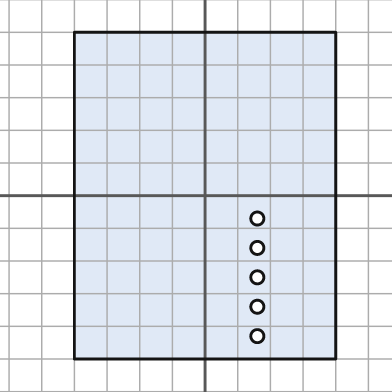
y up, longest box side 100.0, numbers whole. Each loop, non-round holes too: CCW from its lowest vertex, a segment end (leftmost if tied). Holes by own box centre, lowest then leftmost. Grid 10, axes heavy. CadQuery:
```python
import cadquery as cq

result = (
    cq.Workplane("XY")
    .moveTo(-40.0, -50.0)
    .lineTo(40.0, -50.0)
    .lineTo(40.0, 50.0)
    .lineTo(-40.0, 50.0)
    .close()
    .moveTo(16.0, -43.0)
    .circle(2.0)
    .moveTo(16.0, -34.0)
    .circle(2.0)
    .moveTo(16.0, -25.0)
    .circle(2.0)
    .moveTo(16.0, -16.0)
    .circle(2.0)
    .moveTo(16.0, -7.0)
    .circle(2.0)
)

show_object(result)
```